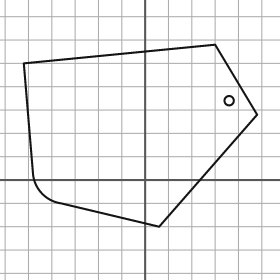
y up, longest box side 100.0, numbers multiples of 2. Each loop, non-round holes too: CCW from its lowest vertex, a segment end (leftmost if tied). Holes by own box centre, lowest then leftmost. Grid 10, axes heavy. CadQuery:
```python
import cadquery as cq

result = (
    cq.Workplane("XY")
    .moveTo(6.0, -20.0)
    .lineTo(48.0, 28.0)
    .lineTo(30.0, 58.0)
    .lineTo(-52.0, 50.0)
    .lineTo(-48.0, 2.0)
    .threePointArc((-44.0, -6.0), (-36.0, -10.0))
    .close()
    .moveTo(36.0, 34.0)
    .circle(2.0)
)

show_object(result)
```